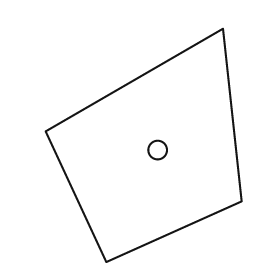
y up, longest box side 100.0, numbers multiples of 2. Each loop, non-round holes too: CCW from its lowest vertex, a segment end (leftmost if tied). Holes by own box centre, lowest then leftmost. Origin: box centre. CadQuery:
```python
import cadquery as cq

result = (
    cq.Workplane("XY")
    .moveTo(-16.0, -50.0)
    .lineTo(42.0, -24.0)
    .lineTo(34.0, 50.0)
    .lineTo(-42.0, 6.0)
    .close()
    .moveTo(6.0, -2.0)
    .circle(4.0)
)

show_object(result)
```